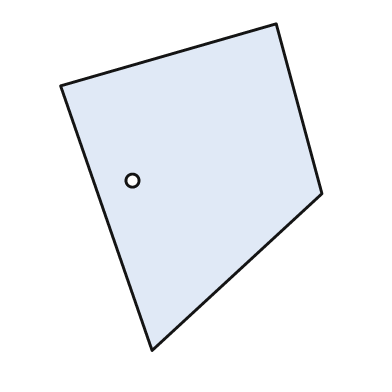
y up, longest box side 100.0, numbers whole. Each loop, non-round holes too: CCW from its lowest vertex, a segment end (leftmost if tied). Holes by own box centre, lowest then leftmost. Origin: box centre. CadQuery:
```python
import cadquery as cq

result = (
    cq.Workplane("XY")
    .moveTo(-12.0, -50.0)
    .lineTo(40.0, -2.0)
    .lineTo(26.0, 50.0)
    .lineTo(-40.0, 31.0)
    .close()
    .moveTo(-18.0, 2.0)
    .circle(2.0)
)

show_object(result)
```